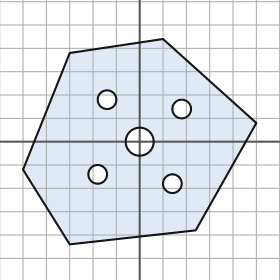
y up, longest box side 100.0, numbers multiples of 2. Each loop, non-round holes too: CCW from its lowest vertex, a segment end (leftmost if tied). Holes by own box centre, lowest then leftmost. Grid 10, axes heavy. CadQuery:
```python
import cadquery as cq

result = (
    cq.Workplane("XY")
    .moveTo(-30.0, -44.0)
    .lineTo(24.0, -38.0)
    .lineTo(50.0, 8.0)
    .lineTo(10.0, 44.0)
    .lineTo(-30.0, 38.0)
    .lineTo(-50.0, -12.0)
    .close()
    .moveTo(14.0, -18.0)
    .circle(4.0)
    .moveTo(-18.0, -14.0)
    .circle(4.0)
    .moveTo(0.0, 0.0)
    .circle(6.0)
    .moveTo(18.0, 14.0)
    .circle(4.0)
    .moveTo(-14.0, 18.0)
    .circle(4.0)
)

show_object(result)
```